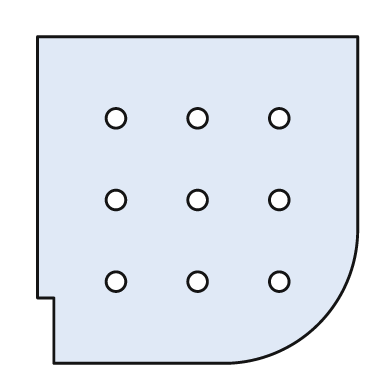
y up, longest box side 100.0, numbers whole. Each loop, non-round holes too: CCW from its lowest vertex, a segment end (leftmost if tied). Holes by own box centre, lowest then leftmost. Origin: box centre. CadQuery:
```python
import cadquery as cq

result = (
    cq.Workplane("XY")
    .moveTo(-44.0, -50.0)
    .lineTo(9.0, -50.0)
    .threePointArc((37.0, -38.0), (49.0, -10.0))
    .lineTo(49.0, 50.0)
    .lineTo(-49.0, 50.0)
    .lineTo(-49.0, -30.0)
    .lineTo(-44.0, -30.0)
    .close()
    .moveTo(-25.0, -25.0)
    .circle(3.0)
    .moveTo(0.0, -25.0)
    .circle(3.0)
    .moveTo(25.0, -25.0)
    .circle(3.0)
    .moveTo(-25.0, 0.0)
    .circle(3.0)
    .moveTo(0.0, 0.0)
    .circle(3.0)
    .moveTo(25.0, 0.0)
    .circle(3.0)
    .moveTo(-25.0, 25.0)
    .circle(3.0)
    .moveTo(0.0, 25.0)
    .circle(3.0)
    .moveTo(25.0, 25.0)
    .circle(3.0)
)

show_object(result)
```